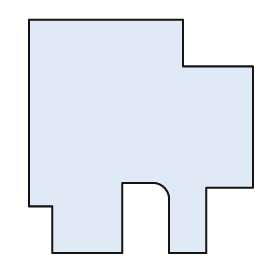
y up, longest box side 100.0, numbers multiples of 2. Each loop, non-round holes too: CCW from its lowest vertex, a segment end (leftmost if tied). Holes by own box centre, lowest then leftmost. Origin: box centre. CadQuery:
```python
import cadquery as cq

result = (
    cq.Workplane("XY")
    .moveTo(-38.0, -50.0)
    .lineTo(-8.0, -50.0)
    .lineTo(-8.0, -20.0)
    .lineTo(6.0, -20.0)
    .threePointArc((10.0, -22.0), (12.0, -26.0))
    .lineTo(12.0, -50.0)
    .lineTo(28.0, -50.0)
    .lineTo(28.0, -22.0)
    .lineTo(48.0, -22.0)
    .lineTo(48.0, 30.0)
    .lineTo(18.0, 30.0)
    .lineTo(18.0, 50.0)
    .lineTo(-48.0, 50.0)
    .lineTo(-48.0, -30.0)
    .lineTo(-38.0, -30.0)
    .close()
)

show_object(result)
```